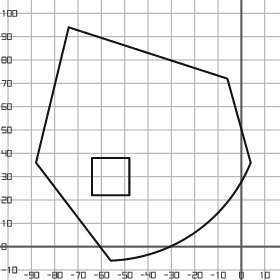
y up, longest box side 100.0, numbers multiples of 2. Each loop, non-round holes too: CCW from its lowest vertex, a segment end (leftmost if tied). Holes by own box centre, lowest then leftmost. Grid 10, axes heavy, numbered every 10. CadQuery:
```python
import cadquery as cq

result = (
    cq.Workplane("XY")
    .moveTo(-56.0, -6.0)
    .threePointArc((-20.0, 6.0), (4.0, 36.0))
    .lineTo(-6.0, 72.0)
    .lineTo(-74.0, 94.0)
    .lineTo(-88.0, 36.0)
    .close()
    .moveTo(-64.0, 22.0)
    .lineTo(-48.0, 22.0)
    .lineTo(-48.0, 38.0)
    .lineTo(-64.0, 38.0)
    .close()
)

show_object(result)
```